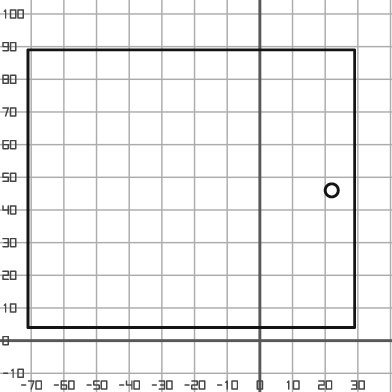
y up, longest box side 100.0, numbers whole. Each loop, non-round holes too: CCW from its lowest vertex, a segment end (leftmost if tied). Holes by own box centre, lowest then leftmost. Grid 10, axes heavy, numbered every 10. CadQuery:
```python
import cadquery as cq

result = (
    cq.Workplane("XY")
    .moveTo(-71.0, 4.0)
    .lineTo(29.0, 4.0)
    .lineTo(29.0, 89.0)
    .lineTo(-71.0, 89.0)
    .close()
    .moveTo(22.0, 46.0)
    .circle(2.0)
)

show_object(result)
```